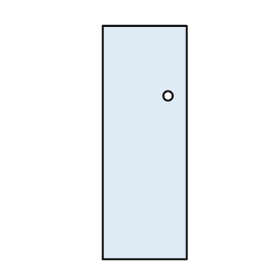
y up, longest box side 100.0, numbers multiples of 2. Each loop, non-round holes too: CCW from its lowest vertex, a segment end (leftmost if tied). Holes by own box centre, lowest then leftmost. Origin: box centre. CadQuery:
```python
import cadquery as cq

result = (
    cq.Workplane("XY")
    .moveTo(-18.0, -50.0)
    .lineTo(18.0, -50.0)
    .lineTo(18.0, 50.0)
    .lineTo(-18.0, 50.0)
    .close()
    .moveTo(10.0, 20.0)
    .circle(2.0)
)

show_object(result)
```